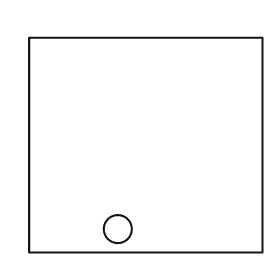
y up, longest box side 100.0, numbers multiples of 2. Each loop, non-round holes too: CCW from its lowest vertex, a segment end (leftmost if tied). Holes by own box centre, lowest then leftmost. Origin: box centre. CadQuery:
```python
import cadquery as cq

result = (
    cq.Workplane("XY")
    .moveTo(-50.0, -46.0)
    .lineTo(50.0, -46.0)
    .lineTo(50.0, 46.0)
    .lineTo(-50.0, 46.0)
    .close()
    .moveTo(-12.0, -36.0)
    .circle(6.0)
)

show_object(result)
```